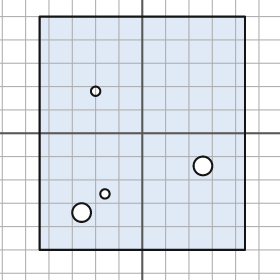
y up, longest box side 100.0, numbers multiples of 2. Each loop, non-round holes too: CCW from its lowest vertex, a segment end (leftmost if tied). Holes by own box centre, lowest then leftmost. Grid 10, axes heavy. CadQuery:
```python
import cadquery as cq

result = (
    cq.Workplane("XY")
    .moveTo(-44.0, -50.0)
    .lineTo(44.0, -50.0)
    .lineTo(44.0, 50.0)
    .lineTo(-44.0, 50.0)
    .close()
    .moveTo(-26.0, -34.0)
    .circle(4.0)
    .moveTo(-16.0, -26.0)
    .circle(2.0)
    .moveTo(26.0, -14.0)
    .circle(4.0)
    .moveTo(-20.0, 18.0)
    .circle(2.0)
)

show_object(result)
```